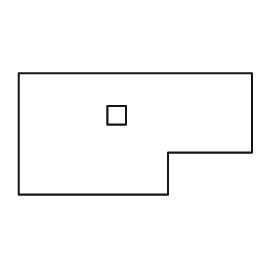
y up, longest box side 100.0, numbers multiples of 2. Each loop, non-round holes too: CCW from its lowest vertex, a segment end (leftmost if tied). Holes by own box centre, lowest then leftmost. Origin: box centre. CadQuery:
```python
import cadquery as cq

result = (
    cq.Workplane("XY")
    .moveTo(-50.0, -26.0)
    .lineTo(14.0, -26.0)
    .lineTo(14.0, -8.0)
    .lineTo(50.0, -8.0)
    .lineTo(50.0, 26.0)
    .lineTo(-50.0, 26.0)
    .close()
    .moveTo(-12.0, 4.0)
    .lineTo(-4.0, 4.0)
    .lineTo(-4.0, 12.0)
    .lineTo(-12.0, 12.0)
    .close()
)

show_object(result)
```